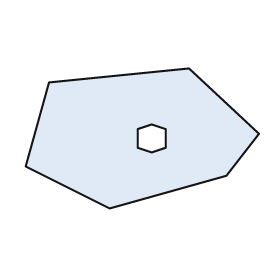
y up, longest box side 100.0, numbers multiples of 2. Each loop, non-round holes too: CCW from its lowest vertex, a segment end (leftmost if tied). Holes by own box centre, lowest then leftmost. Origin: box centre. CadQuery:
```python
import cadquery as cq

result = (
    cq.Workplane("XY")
    .moveTo(-14.0, -30.0)
    .lineTo(36.0, -16.0)
    .lineTo(50.0, 2.0)
    .lineTo(20.0, 30.0)
    .lineTo(-40.0, 24.0)
    .lineTo(-50.0, -12.0)
    .close()
    .moveTo(4.0, -6.0)
    .lineTo(10.0, -4.0)
    .lineTo(10.0, 4.0)
    .lineTo(4.0, 6.0)
    .lineTo(-2.0, 4.0)
    .lineTo(-2.0, -4.0)
    .close()
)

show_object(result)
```